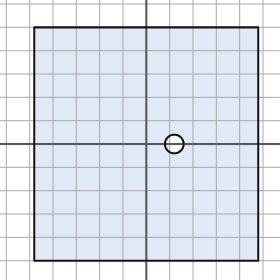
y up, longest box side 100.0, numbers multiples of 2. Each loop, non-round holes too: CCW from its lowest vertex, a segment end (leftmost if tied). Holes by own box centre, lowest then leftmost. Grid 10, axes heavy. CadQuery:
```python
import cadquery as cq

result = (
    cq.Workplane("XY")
    .moveTo(-48.0, -50.0)
    .lineTo(48.0, -50.0)
    .lineTo(48.0, 50.0)
    .lineTo(-48.0, 50.0)
    .close()
    .moveTo(12.0, 0.0)
    .circle(4.0)
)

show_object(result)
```